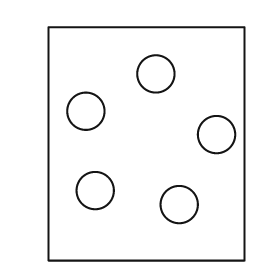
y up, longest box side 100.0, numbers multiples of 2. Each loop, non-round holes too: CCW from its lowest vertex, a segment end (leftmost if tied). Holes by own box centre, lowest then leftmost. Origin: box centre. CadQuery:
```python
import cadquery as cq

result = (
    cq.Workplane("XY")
    .moveTo(-42.0, -50.0)
    .lineTo(42.0, -50.0)
    .lineTo(42.0, 50.0)
    .lineTo(-42.0, 50.0)
    .close()
    .moveTo(14.0, -26.0)
    .circle(8.0)
    .moveTo(-22.0, -20.0)
    .circle(8.0)
    .moveTo(30.0, 4.0)
    .circle(8.0)
    .moveTo(-26.0, 14.0)
    .circle(8.0)
    .moveTo(4.0, 30.0)
    .circle(8.0)
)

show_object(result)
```